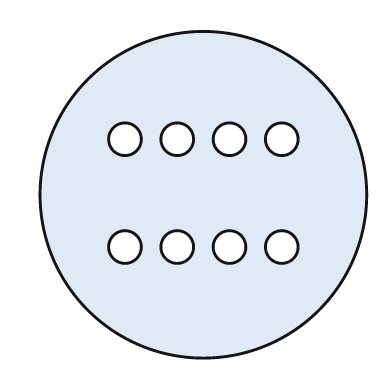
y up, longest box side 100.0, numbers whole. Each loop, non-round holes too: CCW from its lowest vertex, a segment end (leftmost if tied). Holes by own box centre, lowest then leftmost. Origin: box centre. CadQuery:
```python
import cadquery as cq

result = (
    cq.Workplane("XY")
    .moveTo(0.0, 0.0)
    .circle(50.0)
    .moveTo(-24.0, -16.0)
    .circle(5.0)
    .moveTo(-8.0, -16.0)
    .circle(5.0)
    .moveTo(8.0, -16.0)
    .circle(5.0)
    .moveTo(24.0, -16.0)
    .circle(5.0)
    .moveTo(-24.0, 17.0)
    .circle(5.0)
    .moveTo(-8.0, 17.0)
    .circle(5.0)
    .moveTo(8.0, 17.0)
    .circle(5.0)
    .moveTo(24.0, 17.0)
    .circle(5.0)
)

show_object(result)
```